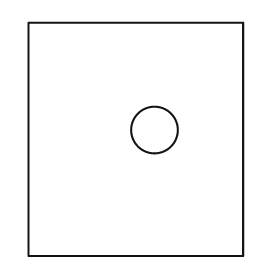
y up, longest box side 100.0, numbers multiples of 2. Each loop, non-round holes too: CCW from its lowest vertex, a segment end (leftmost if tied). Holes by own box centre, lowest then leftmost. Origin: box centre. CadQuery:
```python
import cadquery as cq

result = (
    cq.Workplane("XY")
    .moveTo(-46.0, -50.0)
    .lineTo(46.0, -50.0)
    .lineTo(46.0, 50.0)
    .lineTo(-46.0, 50.0)
    .close()
    .moveTo(8.0, 4.0)
    .circle(10.0)
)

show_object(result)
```